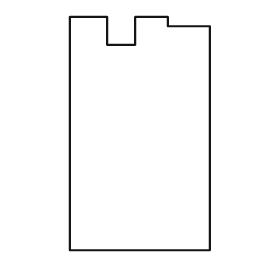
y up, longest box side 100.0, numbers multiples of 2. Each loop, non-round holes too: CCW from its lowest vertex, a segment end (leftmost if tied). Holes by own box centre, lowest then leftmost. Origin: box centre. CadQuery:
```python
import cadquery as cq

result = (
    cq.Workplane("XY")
    .moveTo(-30.0, -50.0)
    .lineTo(30.0, -50.0)
    .lineTo(30.0, 46.0)
    .lineTo(12.0, 46.0)
    .lineTo(12.0, 50.0)
    .lineTo(-2.0, 50.0)
    .lineTo(-2.0, 38.0)
    .lineTo(-14.0, 38.0)
    .lineTo(-14.0, 50.0)
    .lineTo(-30.0, 50.0)
    .close()
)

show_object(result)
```